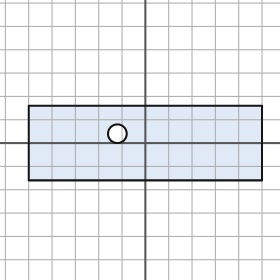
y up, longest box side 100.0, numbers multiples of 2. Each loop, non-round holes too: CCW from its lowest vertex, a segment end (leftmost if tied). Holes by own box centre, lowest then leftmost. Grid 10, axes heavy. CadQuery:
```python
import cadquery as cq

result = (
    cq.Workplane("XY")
    .moveTo(-50.0, -16.0)
    .lineTo(50.0, -16.0)
    .lineTo(50.0, 16.0)
    .lineTo(-50.0, 16.0)
    .close()
    .moveTo(-12.0, 4.0)
    .circle(4.0)
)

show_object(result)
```